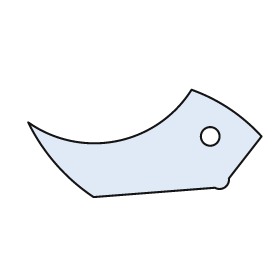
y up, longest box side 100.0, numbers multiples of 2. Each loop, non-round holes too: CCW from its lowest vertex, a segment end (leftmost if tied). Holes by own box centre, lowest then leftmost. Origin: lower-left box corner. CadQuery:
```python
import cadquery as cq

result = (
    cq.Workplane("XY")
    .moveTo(28.0, 0.0)
    .lineTo(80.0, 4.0)
    .threePointArc((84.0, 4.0), (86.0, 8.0))
    .lineTo(100.0, 26.0)
    .threePointArc((86.0, 38.0), (70.0, 46.0))
    .threePointArc((38.0, 24.0), (0.0, 32.0))
    .threePointArc((12.0, 14.0), (28.0, 0.0))
    .close()
    .moveTo(78.0, 26.0)
    .circle(4.0)
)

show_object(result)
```